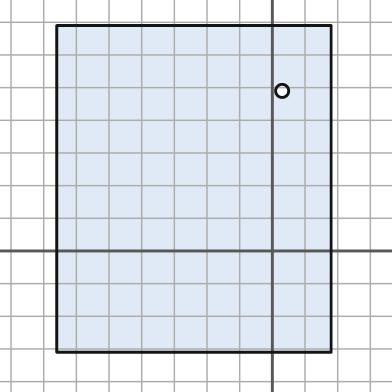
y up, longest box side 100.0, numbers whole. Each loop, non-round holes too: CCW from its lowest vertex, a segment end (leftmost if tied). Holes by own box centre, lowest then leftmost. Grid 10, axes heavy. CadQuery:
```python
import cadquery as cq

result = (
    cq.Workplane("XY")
    .moveTo(-66.0, -31.0)
    .lineTo(18.0, -31.0)
    .lineTo(18.0, 69.0)
    .lineTo(-66.0, 69.0)
    .close()
    .moveTo(3.0, 49.0)
    .circle(2.0)
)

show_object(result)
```